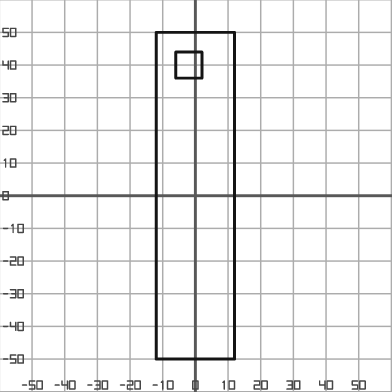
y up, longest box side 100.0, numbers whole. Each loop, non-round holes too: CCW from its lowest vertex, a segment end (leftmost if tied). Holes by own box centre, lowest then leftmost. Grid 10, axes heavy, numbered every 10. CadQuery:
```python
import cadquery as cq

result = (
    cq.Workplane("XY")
    .moveTo(-12.0, -50.0)
    .lineTo(12.0, -50.0)
    .lineTo(12.0, 50.0)
    .lineTo(-12.0, 50.0)
    .close()
    .moveTo(-6.0, 36.0)
    .lineTo(2.0, 36.0)
    .lineTo(2.0, 44.0)
    .lineTo(-6.0, 44.0)
    .close()
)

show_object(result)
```